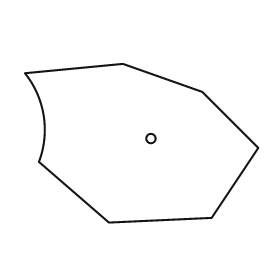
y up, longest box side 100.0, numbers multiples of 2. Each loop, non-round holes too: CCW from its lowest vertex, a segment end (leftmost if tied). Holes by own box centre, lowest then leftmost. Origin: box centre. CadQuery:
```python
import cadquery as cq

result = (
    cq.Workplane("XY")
    .moveTo(-14.0, -34.0)
    .lineTo(30.0, -32.0)
    .lineTo(50.0, -2.0)
    .lineTo(26.0, 22.0)
    .lineTo(-8.0, 34.0)
    .lineTo(-50.0, 30.0)
    .threePointArc((-42.0, 12.0), (-44.0, -8.0))
    .close()
    .moveTo(4.0, 2.0)
    .circle(2.0)
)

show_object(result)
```